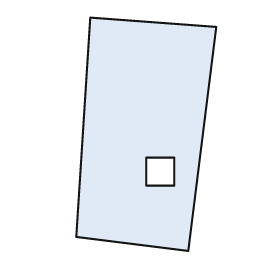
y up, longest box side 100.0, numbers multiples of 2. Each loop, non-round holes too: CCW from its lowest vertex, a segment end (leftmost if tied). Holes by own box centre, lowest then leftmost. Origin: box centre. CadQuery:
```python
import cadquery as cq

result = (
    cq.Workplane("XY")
    .moveTo(18.0, -50.0)
    .lineTo(30.0, 46.0)
    .lineTo(-24.0, 50.0)
    .lineTo(-30.0, -44.0)
    .close()
    .moveTo(0.0, -22.0)
    .lineTo(12.0, -22.0)
    .lineTo(12.0, -10.0)
    .lineTo(0.0, -10.0)
    .close()
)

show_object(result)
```